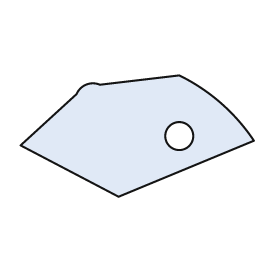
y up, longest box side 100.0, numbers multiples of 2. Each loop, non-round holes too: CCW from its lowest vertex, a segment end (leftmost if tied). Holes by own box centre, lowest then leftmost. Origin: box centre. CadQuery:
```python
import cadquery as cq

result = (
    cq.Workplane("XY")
    .moveTo(-8.0, -26.0)
    .lineTo(50.0, -2.0)
    .threePointArc((36.0, 14.0), (18.0, 26.0))
    .lineTo(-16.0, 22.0)
    .threePointArc((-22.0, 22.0), (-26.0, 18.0))
    .lineTo(-50.0, -4.0)
    .close()
    .moveTo(18.0, 0.0)
    .circle(6.0)
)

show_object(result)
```